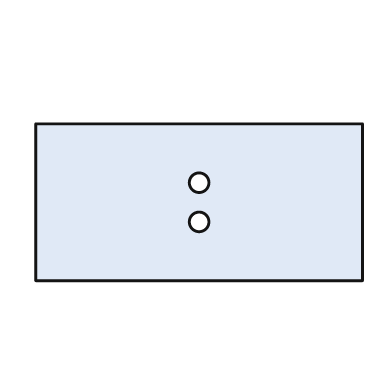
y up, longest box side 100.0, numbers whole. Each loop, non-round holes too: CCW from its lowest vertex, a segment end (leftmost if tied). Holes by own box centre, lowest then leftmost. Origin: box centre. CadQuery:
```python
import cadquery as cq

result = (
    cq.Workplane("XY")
    .moveTo(-50.0, -24.0)
    .lineTo(50.0, -24.0)
    .lineTo(50.0, 24.0)
    .lineTo(-50.0, 24.0)
    .close()
    .moveTo(0.0, -6.0)
    .circle(3.0)
    .moveTo(0.0, 6.0)
    .circle(3.0)
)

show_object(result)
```